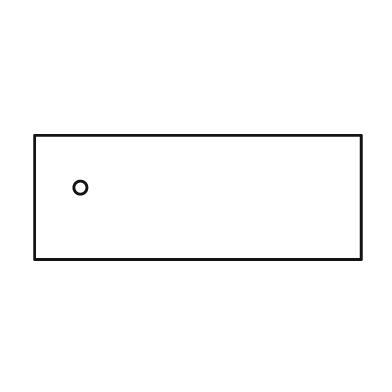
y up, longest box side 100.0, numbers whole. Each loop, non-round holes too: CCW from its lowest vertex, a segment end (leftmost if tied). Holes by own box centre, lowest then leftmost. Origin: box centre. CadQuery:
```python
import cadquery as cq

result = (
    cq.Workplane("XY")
    .moveTo(-50.0, -19.0)
    .lineTo(50.0, -19.0)
    .lineTo(50.0, 19.0)
    .lineTo(-50.0, 19.0)
    .close()
    .moveTo(-36.0, 3.0)
    .circle(2.0)
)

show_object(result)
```